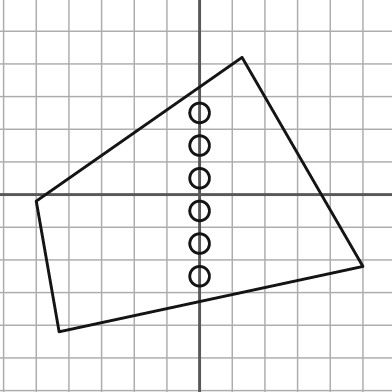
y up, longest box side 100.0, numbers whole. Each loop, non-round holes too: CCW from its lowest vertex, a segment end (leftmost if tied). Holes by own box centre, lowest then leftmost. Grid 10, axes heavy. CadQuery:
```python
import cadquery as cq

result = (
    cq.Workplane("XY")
    .moveTo(-43.0, -42.0)
    .lineTo(50.0, -22.0)
    .lineTo(13.0, 42.0)
    .lineTo(-50.0, -2.0)
    .close()
    .moveTo(0.0, -25.0)
    .circle(3.0)
    .moveTo(0.0, -15.0)
    .circle(3.0)
    .moveTo(0.0, -5.0)
    .circle(3.0)
    .moveTo(0.0, 5.0)
    .circle(3.0)
    .moveTo(0.0, 15.0)
    .circle(3.0)
    .moveTo(0.0, 25.0)
    .circle(3.0)
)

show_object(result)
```